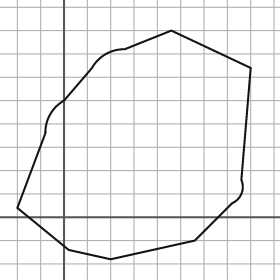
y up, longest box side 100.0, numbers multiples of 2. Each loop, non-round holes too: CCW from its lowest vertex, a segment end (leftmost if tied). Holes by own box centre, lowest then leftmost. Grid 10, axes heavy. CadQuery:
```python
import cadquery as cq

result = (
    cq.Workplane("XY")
    .moveTo(20.0, -18.0)
    .lineTo(56.0, -10.0)
    .lineTo(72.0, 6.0)
    .threePointArc((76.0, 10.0), (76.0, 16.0))
    .lineTo(80.0, 64.0)
    .lineTo(46.0, 80.0)
    .lineTo(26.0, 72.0)
    .threePointArc((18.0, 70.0), (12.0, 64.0))
    .lineTo(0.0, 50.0)
    .threePointArc((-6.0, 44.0), (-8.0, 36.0))
    .lineTo(-20.0, 4.0)
    .lineTo(2.0, -14.0)
    .close()
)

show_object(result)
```